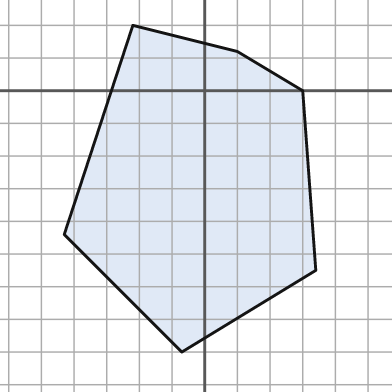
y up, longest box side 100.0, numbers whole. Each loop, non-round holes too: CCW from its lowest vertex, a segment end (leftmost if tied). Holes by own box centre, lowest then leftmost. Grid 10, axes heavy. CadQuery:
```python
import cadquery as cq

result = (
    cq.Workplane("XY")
    .moveTo(-7.0, -80.0)
    .lineTo(34.0, -55.0)
    .lineTo(30.0, 0.0)
    .lineTo(10.0, 12.0)
    .lineTo(-22.0, 20.0)
    .lineTo(-43.0, -44.0)
    .close()
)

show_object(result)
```